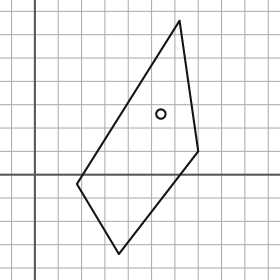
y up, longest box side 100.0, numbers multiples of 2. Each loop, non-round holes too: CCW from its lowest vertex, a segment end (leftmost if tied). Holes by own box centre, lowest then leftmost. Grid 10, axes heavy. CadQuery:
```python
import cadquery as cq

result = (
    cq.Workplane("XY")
    .moveTo(36.0, -34.0)
    .lineTo(70.0, 10.0)
    .lineTo(62.0, 66.0)
    .lineTo(18.0, -4.0)
    .close()
    .moveTo(54.0, 26.0)
    .circle(2.0)
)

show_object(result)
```